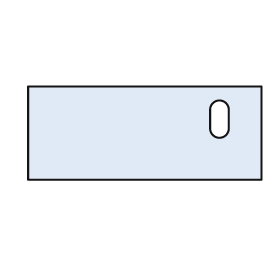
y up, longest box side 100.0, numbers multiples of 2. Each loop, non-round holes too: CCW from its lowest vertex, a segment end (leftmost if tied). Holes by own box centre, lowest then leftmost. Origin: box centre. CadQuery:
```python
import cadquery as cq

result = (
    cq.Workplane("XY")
    .moveTo(-50.0, -20.0)
    .lineTo(50.0, -20.0)
    .lineTo(50.0, 20.0)
    .lineTo(-50.0, 20.0)
    .close()
    .moveTo(28.0, 2.0)
    .threePointArc((32.0, -2.0), (36.0, 2.0))
    .lineTo(36.0, 10.0)
    .threePointArc((32.0, 14.0), (28.0, 10.0))
    .close()
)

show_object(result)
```